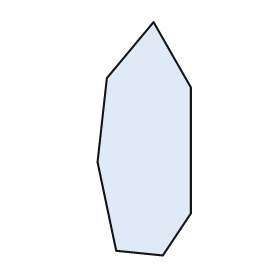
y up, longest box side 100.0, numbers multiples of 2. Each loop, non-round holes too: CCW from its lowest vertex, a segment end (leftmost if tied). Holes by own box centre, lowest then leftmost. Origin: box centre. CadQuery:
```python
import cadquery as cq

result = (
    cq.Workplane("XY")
    .moveTo(8.0, -50.0)
    .lineTo(20.0, -32.0)
    .lineTo(20.0, 22.0)
    .lineTo(4.0, 50.0)
    .lineTo(-16.0, 26.0)
    .lineTo(-20.0, -10.0)
    .lineTo(-12.0, -48.0)
    .close()
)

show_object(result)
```